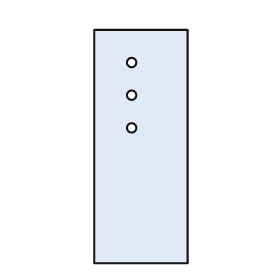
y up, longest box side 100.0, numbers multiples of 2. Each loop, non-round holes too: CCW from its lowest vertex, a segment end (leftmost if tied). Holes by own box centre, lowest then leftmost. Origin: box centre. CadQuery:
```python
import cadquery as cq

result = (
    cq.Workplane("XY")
    .moveTo(-20.0, -50.0)
    .lineTo(20.0, -50.0)
    .lineTo(20.0, 50.0)
    .lineTo(-20.0, 50.0)
    .close()
    .moveTo(-4.0, 8.0)
    .circle(2.0)
    .moveTo(-4.0, 22.0)
    .circle(2.0)
    .moveTo(-4.0, 36.0)
    .circle(2.0)
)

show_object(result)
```